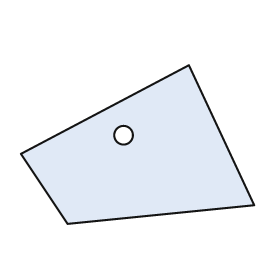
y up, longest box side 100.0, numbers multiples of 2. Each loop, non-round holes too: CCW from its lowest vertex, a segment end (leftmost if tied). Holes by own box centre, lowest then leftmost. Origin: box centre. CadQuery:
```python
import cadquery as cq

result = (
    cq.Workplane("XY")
    .moveTo(-30.0, -34.0)
    .lineTo(50.0, -26.0)
    .lineTo(22.0, 34.0)
    .lineTo(-50.0, -4.0)
    .close()
    .moveTo(-6.0, 4.0)
    .circle(4.0)
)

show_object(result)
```